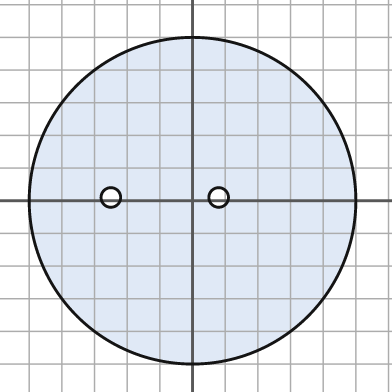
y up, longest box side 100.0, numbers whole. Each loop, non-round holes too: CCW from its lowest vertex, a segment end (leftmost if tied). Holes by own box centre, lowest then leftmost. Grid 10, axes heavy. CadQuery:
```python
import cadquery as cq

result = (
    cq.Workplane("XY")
    .moveTo(0.0, 0.0)
    .circle(50.0)
    .moveTo(-25.0, 1.0)
    .circle(3.0)
    .moveTo(8.0, 1.0)
    .circle(3.0)
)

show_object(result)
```